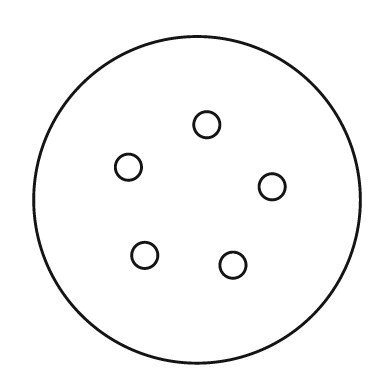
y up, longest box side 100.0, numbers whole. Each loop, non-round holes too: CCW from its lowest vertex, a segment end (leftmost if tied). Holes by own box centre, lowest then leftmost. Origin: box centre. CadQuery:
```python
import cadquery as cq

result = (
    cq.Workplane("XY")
    .moveTo(0.0, 0.0)
    .circle(50.0)
    .moveTo(11.0, -20.0)
    .circle(4.0)
    .moveTo(-16.0, -17.0)
    .circle(4.0)
    .moveTo(23.0, 4.0)
    .circle(4.0)
    .moveTo(-21.0, 10.0)
    .circle(4.0)
    .moveTo(3.0, 23.0)
    .circle(4.0)
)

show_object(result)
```